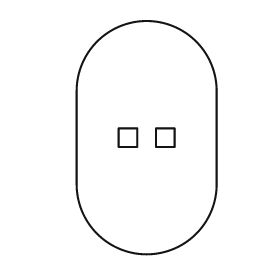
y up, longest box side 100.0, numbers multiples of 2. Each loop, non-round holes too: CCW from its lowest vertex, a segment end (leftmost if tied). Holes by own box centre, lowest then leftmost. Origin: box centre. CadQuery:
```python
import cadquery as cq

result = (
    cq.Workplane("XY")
    .moveTo(-30.0, -20.0)
    .threePointArc((0.0, -50.0), (30.0, -20.0))
    .lineTo(30.0, 20.0)
    .threePointArc((0.0, 50.0), (-30.0, 20.0))
    .close()
    .moveTo(-12.0, -4.0)
    .lineTo(-4.0, -4.0)
    .lineTo(-4.0, 4.0)
    .lineTo(-12.0, 4.0)
    .close()
    .moveTo(4.0, -4.0)
    .lineTo(12.0, -4.0)
    .lineTo(12.0, 4.0)
    .lineTo(4.0, 4.0)
    .close()
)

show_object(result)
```